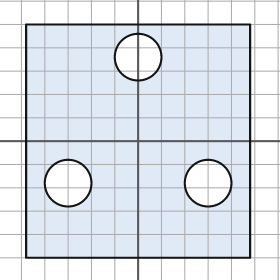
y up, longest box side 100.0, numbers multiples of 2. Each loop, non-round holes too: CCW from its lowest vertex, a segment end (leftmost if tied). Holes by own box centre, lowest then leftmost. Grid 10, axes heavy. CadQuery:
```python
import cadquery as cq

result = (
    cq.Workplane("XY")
    .moveTo(-48.0, -50.0)
    .lineTo(48.0, -50.0)
    .lineTo(48.0, 50.0)
    .lineTo(-48.0, 50.0)
    .close()
    .moveTo(-30.0, -18.0)
    .circle(10.0)
    .moveTo(30.0, -18.0)
    .circle(10.0)
    .moveTo(0.0, 36.0)
    .circle(10.0)
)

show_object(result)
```